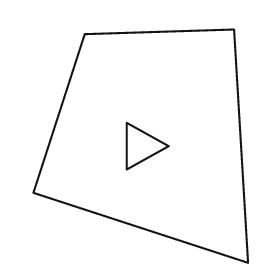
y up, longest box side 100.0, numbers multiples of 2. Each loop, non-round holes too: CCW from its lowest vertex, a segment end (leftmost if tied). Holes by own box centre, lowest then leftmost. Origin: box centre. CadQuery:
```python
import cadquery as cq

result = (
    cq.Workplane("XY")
    .moveTo(46.0, -50.0)
    .lineTo(40.0, 50.0)
    .lineTo(-24.0, 48.0)
    .lineTo(-46.0, -20.0)
    .close()
    .moveTo(-6.0, -10.0)
    .lineTo(12.0, 0.0)
    .lineTo(-6.0, 10.0)
    .close()
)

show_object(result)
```